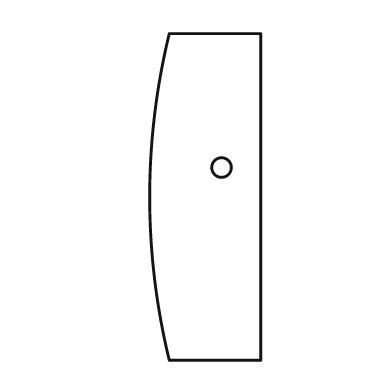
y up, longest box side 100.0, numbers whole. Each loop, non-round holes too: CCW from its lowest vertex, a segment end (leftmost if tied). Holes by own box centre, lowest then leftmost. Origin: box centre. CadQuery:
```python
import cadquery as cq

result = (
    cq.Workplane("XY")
    .moveTo(-11.0, -50.0)
    .lineTo(17.0, -50.0)
    .lineTo(17.0, 50.0)
    .lineTo(-11.0, 50.0)
    .threePointArc((-17.0, 0.0), (-11.0, -50.0))
    .close()
    .moveTo(5.0, 9.0)
    .circle(3.0)
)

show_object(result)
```